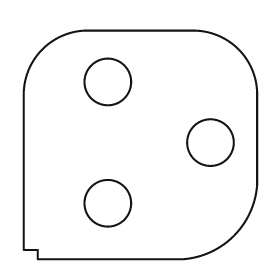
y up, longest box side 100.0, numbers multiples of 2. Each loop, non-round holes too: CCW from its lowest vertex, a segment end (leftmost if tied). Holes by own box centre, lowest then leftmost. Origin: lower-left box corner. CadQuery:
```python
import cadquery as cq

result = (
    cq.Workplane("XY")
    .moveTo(6.0, 0.0)
    .lineTo(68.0, 0.0)
    .threePointArc((90.0, 10.0), (100.0, 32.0))
    .lineTo(100.0, 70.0)
    .threePointArc((92.0, 90.0), (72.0, 98.0))
    .lineTo(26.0, 98.0)
    .threePointArc((8.0, 90.0), (0.0, 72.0))
    .lineTo(0.0, 4.0)
    .lineTo(6.0, 4.0)
    .close()
    .moveTo(36.0, 24.0)
    .circle(10.0)
    .moveTo(80.0, 50.0)
    .circle(10.0)
    .moveTo(36.0, 76.0)
    .circle(10.0)
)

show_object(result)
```